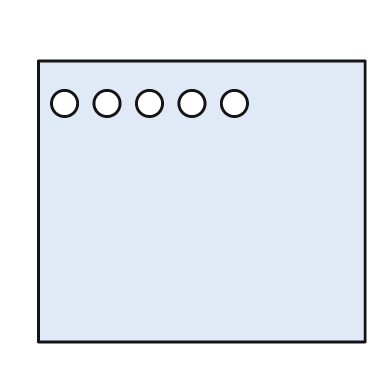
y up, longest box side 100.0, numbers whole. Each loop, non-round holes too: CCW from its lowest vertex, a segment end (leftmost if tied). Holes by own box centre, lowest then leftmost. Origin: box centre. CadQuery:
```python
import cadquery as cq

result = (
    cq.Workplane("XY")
    .moveTo(-50.0, -43.0)
    .lineTo(50.0, -43.0)
    .lineTo(50.0, 43.0)
    .lineTo(-50.0, 43.0)
    .close()
    .moveTo(-42.0, 30.0)
    .circle(4.0)
    .moveTo(-29.0, 30.0)
    .circle(4.0)
    .moveTo(-16.0, 30.0)
    .circle(4.0)
    .moveTo(-3.0, 30.0)
    .circle(4.0)
    .moveTo(10.0, 30.0)
    .circle(4.0)
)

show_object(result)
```